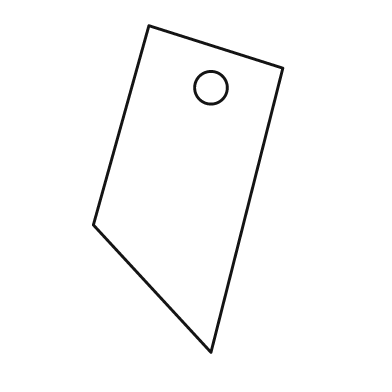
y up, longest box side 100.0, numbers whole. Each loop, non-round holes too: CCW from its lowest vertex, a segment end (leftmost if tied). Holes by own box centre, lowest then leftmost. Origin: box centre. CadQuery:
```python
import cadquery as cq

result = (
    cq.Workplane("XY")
    .moveTo(7.0, -50.0)
    .lineTo(29.0, 37.0)
    .lineTo(-12.0, 50.0)
    .lineTo(-29.0, -11.0)
    .close()
    .moveTo(7.0, 31.0)
    .circle(5.0)
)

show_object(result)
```